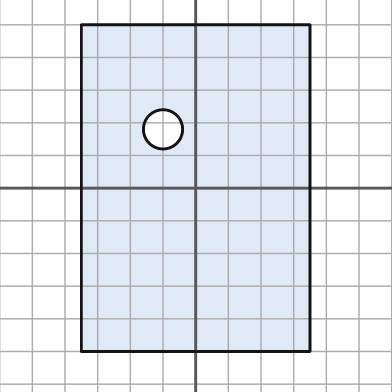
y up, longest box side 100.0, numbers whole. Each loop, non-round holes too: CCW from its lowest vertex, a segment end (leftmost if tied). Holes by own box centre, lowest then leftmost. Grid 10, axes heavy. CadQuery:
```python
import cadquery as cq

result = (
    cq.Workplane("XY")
    .moveTo(-35.0, -50.0)
    .lineTo(35.0, -50.0)
    .lineTo(35.0, 50.0)
    .lineTo(-35.0, 50.0)
    .close()
    .moveTo(-10.0, 18.0)
    .circle(6.0)
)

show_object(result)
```